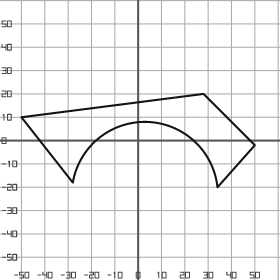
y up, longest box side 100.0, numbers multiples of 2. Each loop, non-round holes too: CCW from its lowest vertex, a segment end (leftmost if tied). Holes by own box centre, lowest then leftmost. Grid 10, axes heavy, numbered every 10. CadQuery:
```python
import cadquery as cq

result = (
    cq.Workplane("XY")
    .moveTo(34.0, -20.0)
    .lineTo(50.0, -2.0)
    .lineTo(28.0, 20.0)
    .lineTo(-50.0, 10.0)
    .lineTo(-28.0, -18.0)
    .threePointArc((4.0, 8.0), (34.0, -20.0))
    .close()
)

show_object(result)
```